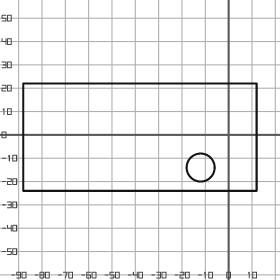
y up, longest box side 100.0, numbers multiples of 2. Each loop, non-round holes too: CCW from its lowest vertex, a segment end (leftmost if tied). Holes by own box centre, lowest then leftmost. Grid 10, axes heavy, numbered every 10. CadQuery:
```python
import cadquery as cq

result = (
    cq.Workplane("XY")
    .moveTo(-88.0, -24.0)
    .lineTo(12.0, -24.0)
    .lineTo(12.0, 22.0)
    .lineTo(-88.0, 22.0)
    .close()
    .moveTo(-12.0, -14.0)
    .circle(6.0)
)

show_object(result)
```